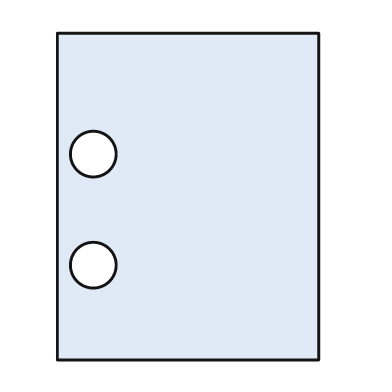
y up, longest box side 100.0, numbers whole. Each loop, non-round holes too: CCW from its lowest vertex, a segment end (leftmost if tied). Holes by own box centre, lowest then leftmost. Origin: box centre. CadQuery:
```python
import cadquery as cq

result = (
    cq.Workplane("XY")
    .moveTo(-40.0, -50.0)
    .lineTo(40.0, -50.0)
    .lineTo(40.0, 50.0)
    .lineTo(-40.0, 50.0)
    .close()
    .moveTo(-29.0, -21.0)
    .circle(7.0)
    .moveTo(-29.0, 13.0)
    .circle(7.0)
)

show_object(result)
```